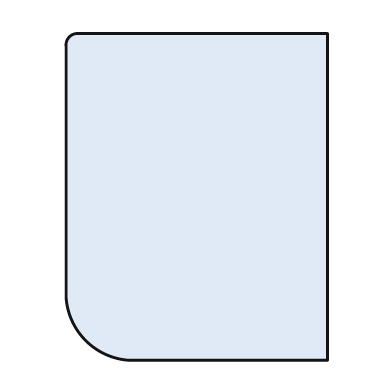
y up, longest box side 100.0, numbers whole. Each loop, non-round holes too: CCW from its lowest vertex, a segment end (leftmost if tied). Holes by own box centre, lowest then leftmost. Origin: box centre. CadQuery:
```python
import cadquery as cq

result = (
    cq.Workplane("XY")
    .moveTo(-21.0, -50.0)
    .lineTo(40.0, -50.0)
    .lineTo(40.0, 50.0)
    .lineTo(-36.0, 50.0)
    .threePointArc((-39.0, 49.0), (-40.0, 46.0))
    .lineTo(-40.0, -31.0)
    .threePointArc((-34.0, -44.0), (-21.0, -50.0))
    .close()
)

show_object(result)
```